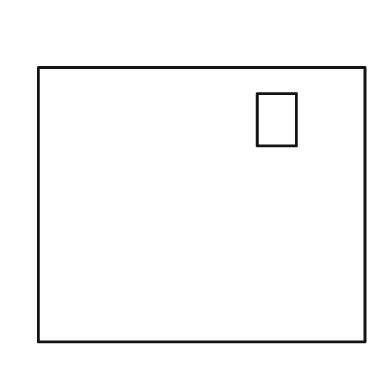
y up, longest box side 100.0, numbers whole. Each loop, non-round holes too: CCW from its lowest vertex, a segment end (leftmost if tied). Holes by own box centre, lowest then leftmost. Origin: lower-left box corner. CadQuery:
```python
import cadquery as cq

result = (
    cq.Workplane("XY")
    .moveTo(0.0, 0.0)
    .lineTo(100.0, 0.0)
    .lineTo(100.0, 84.0)
    .lineTo(0.0, 84.0)
    .close()
    .moveTo(67.0, 60.0)
    .lineTo(79.0, 60.0)
    .lineTo(79.0, 76.0)
    .lineTo(67.0, 76.0)
    .close()
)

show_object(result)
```